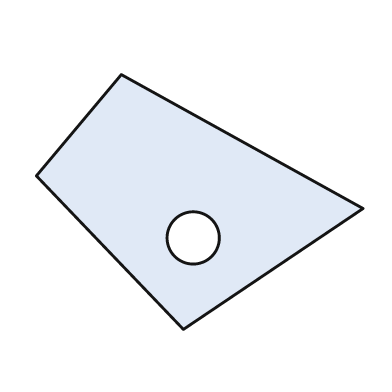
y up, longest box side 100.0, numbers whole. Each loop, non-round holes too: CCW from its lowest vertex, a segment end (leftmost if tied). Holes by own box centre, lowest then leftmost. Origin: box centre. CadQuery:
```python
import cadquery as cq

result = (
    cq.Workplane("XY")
    .moveTo(-5.0, -39.0)
    .lineTo(50.0, -2.0)
    .lineTo(-24.0, 39.0)
    .lineTo(-50.0, 8.0)
    .close()
    .moveTo(-2.0, -11.0)
    .circle(8.0)
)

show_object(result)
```